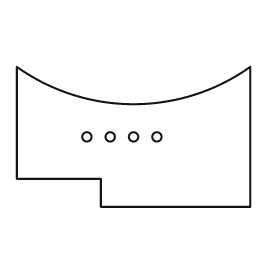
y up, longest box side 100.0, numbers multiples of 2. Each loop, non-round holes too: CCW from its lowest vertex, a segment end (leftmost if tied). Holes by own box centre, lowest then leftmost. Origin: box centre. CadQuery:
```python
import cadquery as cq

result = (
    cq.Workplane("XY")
    .moveTo(-14.0, -30.0)
    .lineTo(50.0, -30.0)
    .lineTo(50.0, 30.0)
    .threePointArc((0.0, 14.0), (-50.0, 30.0))
    .lineTo(-50.0, -18.0)
    .lineTo(-14.0, -18.0)
    .close()
    .moveTo(-20.0, 0.0)
    .circle(2.0)
    .moveTo(-10.0, 0.0)
    .circle(2.0)
    .moveTo(0.0, 0.0)
    .circle(2.0)
    .moveTo(10.0, 0.0)
    .circle(2.0)
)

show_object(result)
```